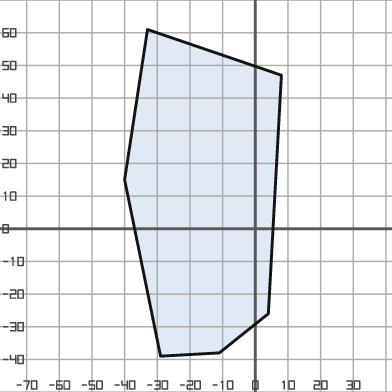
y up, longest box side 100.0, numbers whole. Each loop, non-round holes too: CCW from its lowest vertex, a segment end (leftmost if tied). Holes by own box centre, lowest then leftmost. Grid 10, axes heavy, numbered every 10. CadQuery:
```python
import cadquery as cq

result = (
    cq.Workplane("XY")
    .moveTo(-29.0, -39.0)
    .lineTo(-11.0, -38.0)
    .lineTo(4.0, -26.0)
    .lineTo(8.0, 47.0)
    .lineTo(-33.0, 61.0)
    .lineTo(-40.0, 15.0)
    .close()
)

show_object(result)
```